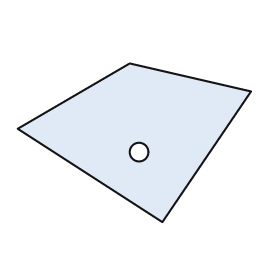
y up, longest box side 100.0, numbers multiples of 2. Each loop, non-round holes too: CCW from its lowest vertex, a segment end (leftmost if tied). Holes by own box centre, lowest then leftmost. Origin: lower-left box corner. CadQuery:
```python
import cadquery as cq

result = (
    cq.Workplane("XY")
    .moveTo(62.0, 0.0)
    .lineTo(100.0, 56.0)
    .lineTo(48.0, 68.0)
    .lineTo(0.0, 40.0)
    .close()
    .moveTo(52.0, 30.0)
    .circle(4.0)
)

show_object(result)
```